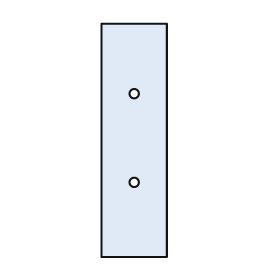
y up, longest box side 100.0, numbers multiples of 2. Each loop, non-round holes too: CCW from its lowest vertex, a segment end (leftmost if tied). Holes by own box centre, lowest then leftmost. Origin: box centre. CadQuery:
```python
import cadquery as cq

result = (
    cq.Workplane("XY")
    .moveTo(-14.0, -50.0)
    .lineTo(14.0, -50.0)
    .lineTo(14.0, 50.0)
    .lineTo(-14.0, 50.0)
    .close()
    .moveTo(0.0, -18.0)
    .circle(2.0)
    .moveTo(0.0, 20.0)
    .circle(2.0)
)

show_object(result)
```